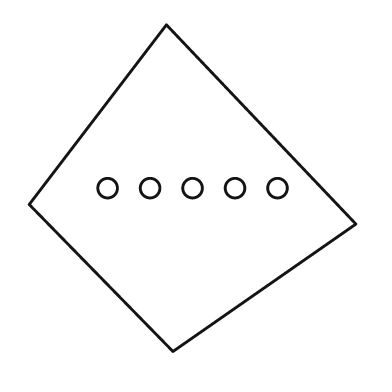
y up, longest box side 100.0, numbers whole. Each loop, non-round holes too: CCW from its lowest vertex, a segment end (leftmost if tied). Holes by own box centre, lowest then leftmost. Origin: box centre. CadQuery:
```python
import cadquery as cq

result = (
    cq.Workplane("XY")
    .moveTo(-6.0, -50.0)
    .lineTo(50.0, -11.0)
    .lineTo(-8.0, 50.0)
    .lineTo(-50.0, -5.0)
    .close()
    .moveTo(-26.0, 0.0)
    .circle(3.0)
    .moveTo(-13.0, 0.0)
    .circle(3.0)
    .moveTo(0.0, 0.0)
    .circle(3.0)
    .moveTo(13.0, 0.0)
    .circle(3.0)
    .moveTo(26.0, 0.0)
    .circle(3.0)
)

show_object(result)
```